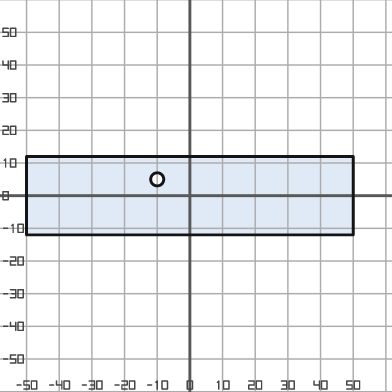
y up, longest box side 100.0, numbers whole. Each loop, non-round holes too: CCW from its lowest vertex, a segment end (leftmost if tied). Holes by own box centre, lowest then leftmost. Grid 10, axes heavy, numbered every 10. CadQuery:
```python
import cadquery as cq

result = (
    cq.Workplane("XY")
    .moveTo(-50.0, -12.0)
    .lineTo(50.0, -12.0)
    .lineTo(50.0, 12.0)
    .lineTo(-50.0, 12.0)
    .close()
    .moveTo(-10.0, 5.0)
    .circle(2.0)
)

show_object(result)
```